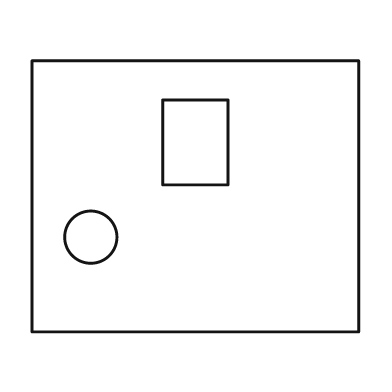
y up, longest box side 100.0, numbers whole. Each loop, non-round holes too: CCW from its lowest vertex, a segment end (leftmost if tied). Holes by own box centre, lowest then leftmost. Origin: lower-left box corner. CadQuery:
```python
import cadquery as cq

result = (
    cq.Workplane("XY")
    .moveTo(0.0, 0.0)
    .lineTo(100.0, 0.0)
    .lineTo(100.0, 83.0)
    .lineTo(0.0, 83.0)
    .close()
    .moveTo(18.0, 29.0)
    .circle(8.0)
    .moveTo(40.0, 45.0)
    .lineTo(60.0, 45.0)
    .lineTo(60.0, 71.0)
    .lineTo(40.0, 71.0)
    .close()
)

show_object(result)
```